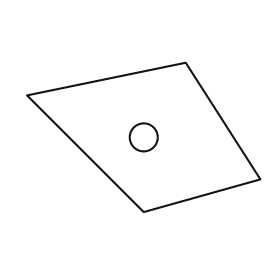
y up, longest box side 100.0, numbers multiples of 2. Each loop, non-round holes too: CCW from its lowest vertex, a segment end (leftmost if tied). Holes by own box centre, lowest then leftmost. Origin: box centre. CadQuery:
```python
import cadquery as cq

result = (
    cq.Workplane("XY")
    .moveTo(0.0, -32.0)
    .lineTo(50.0, -18.0)
    .lineTo(18.0, 32.0)
    .lineTo(-50.0, 18.0)
    .close()
    .moveTo(0.0, 0.0)
    .circle(6.0)
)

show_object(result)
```